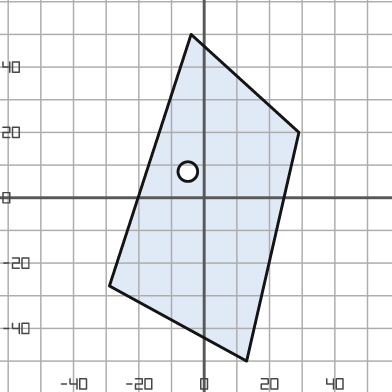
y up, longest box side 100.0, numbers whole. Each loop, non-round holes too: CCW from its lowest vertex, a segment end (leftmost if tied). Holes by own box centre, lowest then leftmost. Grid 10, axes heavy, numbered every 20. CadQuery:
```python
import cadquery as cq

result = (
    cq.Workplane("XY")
    .moveTo(13.0, -50.0)
    .lineTo(29.0, 20.0)
    .lineTo(-4.0, 50.0)
    .lineTo(-29.0, -27.0)
    .close()
    .moveTo(-5.0, 8.0)
    .circle(3.0)
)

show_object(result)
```